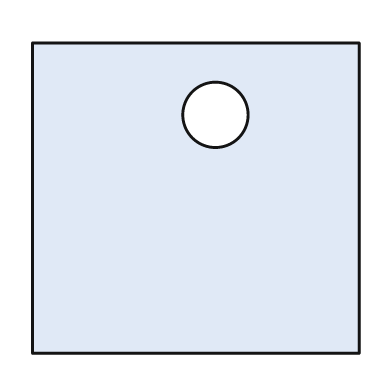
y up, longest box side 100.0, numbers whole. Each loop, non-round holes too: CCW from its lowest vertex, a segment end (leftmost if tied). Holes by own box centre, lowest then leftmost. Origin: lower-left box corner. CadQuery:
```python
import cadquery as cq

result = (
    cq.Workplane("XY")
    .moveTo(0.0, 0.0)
    .lineTo(100.0, 0.0)
    .lineTo(100.0, 95.0)
    .lineTo(0.0, 95.0)
    .close()
    .moveTo(56.0, 73.0)
    .circle(10.0)
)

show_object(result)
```